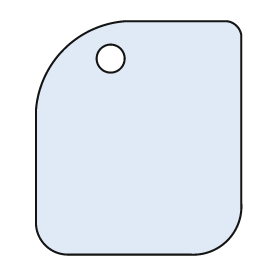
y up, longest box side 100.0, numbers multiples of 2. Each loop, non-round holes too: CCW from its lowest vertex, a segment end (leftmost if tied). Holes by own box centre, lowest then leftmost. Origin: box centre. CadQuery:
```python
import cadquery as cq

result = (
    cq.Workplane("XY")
    .moveTo(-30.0, -50.0)
    .lineTo(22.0, -50.0)
    .threePointArc((38.0, -44.0), (44.0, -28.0))
    .lineTo(44.0, 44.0)
    .threePointArc((42.0, 48.0), (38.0, 50.0))
    .lineTo(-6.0, 50.0)
    .threePointArc((-32.0, 38.0), (-44.0, 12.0))
    .lineTo(-44.0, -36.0)
    .threePointArc((-40.0, -46.0), (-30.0, -50.0))
    .close()
    .moveTo(-12.0, 34.0)
    .circle(6.0)
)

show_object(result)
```